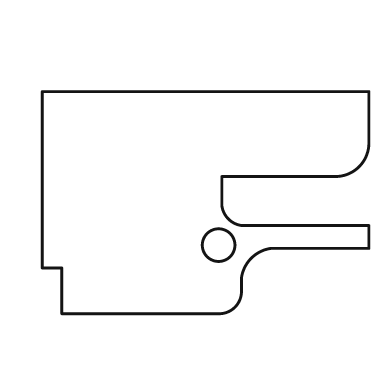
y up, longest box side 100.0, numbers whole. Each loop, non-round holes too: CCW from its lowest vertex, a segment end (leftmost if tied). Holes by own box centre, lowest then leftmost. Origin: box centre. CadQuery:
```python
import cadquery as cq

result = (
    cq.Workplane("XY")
    .moveTo(-44.0, -34.0)
    .lineTo(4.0, -34.0)
    .threePointArc((9.0, -32.0), (11.0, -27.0))
    .lineTo(11.0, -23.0)
    .threePointArc((14.0, -17.0), (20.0, -14.0))
    .lineTo(50.0, -14.0)
    .lineTo(50.0, -7.0)
    .lineTo(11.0, -7.0)
    .threePointArc((7.0, -5.0), (5.0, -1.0))
    .lineTo(5.0, 8.0)
    .lineTo(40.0, 8.0)
    .threePointArc((47.0, 11.0), (50.0, 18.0))
    .lineTo(50.0, 34.0)
    .lineTo(-50.0, 34.0)
    .lineTo(-50.0, -20.0)
    .lineTo(-44.0, -20.0)
    .close()
    .moveTo(4.0, -13.0)
    .circle(5.0)
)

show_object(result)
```